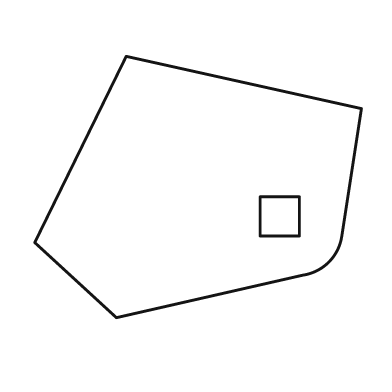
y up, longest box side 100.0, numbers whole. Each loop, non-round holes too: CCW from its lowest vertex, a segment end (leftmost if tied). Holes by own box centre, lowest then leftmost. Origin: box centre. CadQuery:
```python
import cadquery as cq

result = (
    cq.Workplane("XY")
    .moveTo(-25.0, -40.0)
    .lineTo(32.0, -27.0)
    .threePointArc((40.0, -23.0), (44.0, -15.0))
    .lineTo(50.0, 24.0)
    .lineTo(-22.0, 40.0)
    .lineTo(-50.0, -17.0)
    .close()
    .moveTo(19.0, -15.0)
    .lineTo(31.0, -15.0)
    .lineTo(31.0, -3.0)
    .lineTo(19.0, -3.0)
    .close()
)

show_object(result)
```